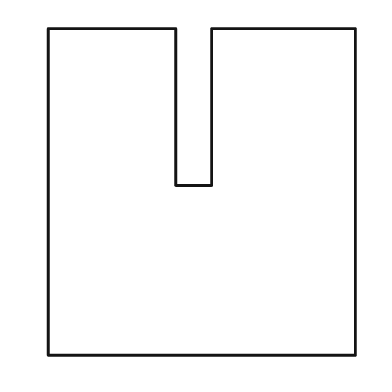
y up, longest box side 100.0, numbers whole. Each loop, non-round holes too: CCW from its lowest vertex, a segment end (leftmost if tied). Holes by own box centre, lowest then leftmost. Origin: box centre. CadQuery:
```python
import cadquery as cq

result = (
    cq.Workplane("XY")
    .moveTo(-47.0, -50.0)
    .lineTo(47.0, -50.0)
    .lineTo(47.0, 50.0)
    .lineTo(3.0, 50.0)
    .lineTo(3.0, 2.0)
    .lineTo(-8.0, 2.0)
    .lineTo(-8.0, 50.0)
    .lineTo(-47.0, 50.0)
    .close()
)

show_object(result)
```